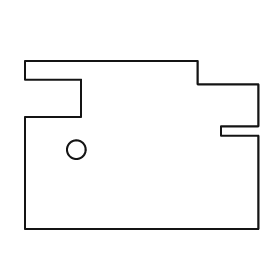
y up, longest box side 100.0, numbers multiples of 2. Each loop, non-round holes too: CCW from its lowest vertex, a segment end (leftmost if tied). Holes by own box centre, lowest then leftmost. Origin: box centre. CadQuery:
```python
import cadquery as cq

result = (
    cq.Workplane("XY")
    .moveTo(-50.0, -36.0)
    .lineTo(50.0, -36.0)
    .lineTo(50.0, 4.0)
    .lineTo(34.0, 4.0)
    .lineTo(34.0, 8.0)
    .lineTo(50.0, 8.0)
    .lineTo(50.0, 26.0)
    .lineTo(24.0, 26.0)
    .lineTo(24.0, 36.0)
    .lineTo(-50.0, 36.0)
    .lineTo(-50.0, 28.0)
    .lineTo(-26.0, 28.0)
    .lineTo(-26.0, 12.0)
    .lineTo(-50.0, 12.0)
    .close()
    .moveTo(-28.0, -2.0)
    .circle(4.0)
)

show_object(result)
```